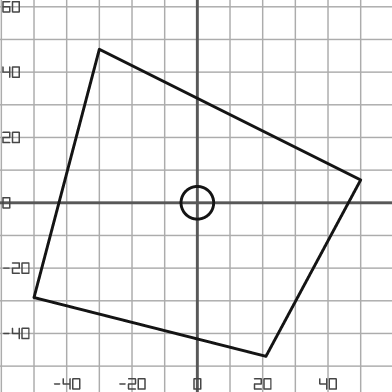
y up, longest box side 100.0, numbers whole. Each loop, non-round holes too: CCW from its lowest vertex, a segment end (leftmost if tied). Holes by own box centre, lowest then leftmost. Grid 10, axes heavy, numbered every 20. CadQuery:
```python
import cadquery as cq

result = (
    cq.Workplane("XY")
    .moveTo(21.0, -47.0)
    .lineTo(50.0, 7.0)
    .lineTo(-30.0, 47.0)
    .lineTo(-50.0, -29.0)
    .close()
    .moveTo(0.0, 0.0)
    .circle(5.0)
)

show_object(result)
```